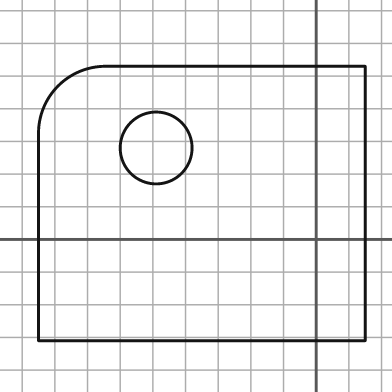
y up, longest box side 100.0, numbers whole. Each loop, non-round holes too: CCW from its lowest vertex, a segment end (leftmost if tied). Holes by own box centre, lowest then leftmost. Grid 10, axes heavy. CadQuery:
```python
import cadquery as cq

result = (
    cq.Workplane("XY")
    .moveTo(-85.0, -31.0)
    .lineTo(15.0, -31.0)
    .lineTo(15.0, 53.0)
    .lineTo(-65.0, 53.0)
    .threePointArc((-79.0, 47.0), (-85.0, 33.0))
    .close()
    .moveTo(-49.0, 28.0)
    .circle(11.0)
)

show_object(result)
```